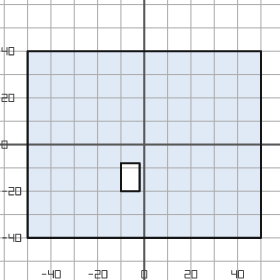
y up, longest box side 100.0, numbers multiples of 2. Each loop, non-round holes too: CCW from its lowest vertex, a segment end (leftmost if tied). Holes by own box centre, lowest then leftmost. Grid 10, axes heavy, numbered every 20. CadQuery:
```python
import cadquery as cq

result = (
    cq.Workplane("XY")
    .moveTo(-50.0, -40.0)
    .lineTo(50.0, -40.0)
    .lineTo(50.0, 40.0)
    .lineTo(-50.0, 40.0)
    .close()
    .moveTo(-10.0, -20.0)
    .lineTo(-2.0, -20.0)
    .lineTo(-2.0, -8.0)
    .lineTo(-10.0, -8.0)
    .close()
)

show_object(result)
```